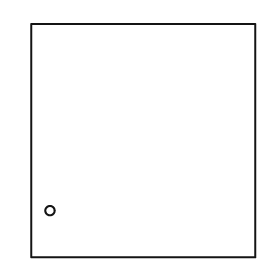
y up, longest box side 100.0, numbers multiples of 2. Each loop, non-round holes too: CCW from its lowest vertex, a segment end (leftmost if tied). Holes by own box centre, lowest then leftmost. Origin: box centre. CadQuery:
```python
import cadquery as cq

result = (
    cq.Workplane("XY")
    .moveTo(-48.0, -50.0)
    .lineTo(48.0, -50.0)
    .lineTo(48.0, 50.0)
    .lineTo(-48.0, 50.0)
    .close()
    .moveTo(-40.0, -30.0)
    .circle(2.0)
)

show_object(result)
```